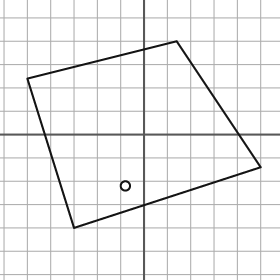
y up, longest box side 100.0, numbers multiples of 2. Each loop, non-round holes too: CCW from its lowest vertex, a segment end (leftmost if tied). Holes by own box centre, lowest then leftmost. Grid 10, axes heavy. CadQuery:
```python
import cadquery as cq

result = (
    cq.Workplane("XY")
    .moveTo(-30.0, -40.0)
    .lineTo(50.0, -14.0)
    .lineTo(14.0, 40.0)
    .lineTo(-50.0, 24.0)
    .close()
    .moveTo(-8.0, -22.0)
    .circle(2.0)
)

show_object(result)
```